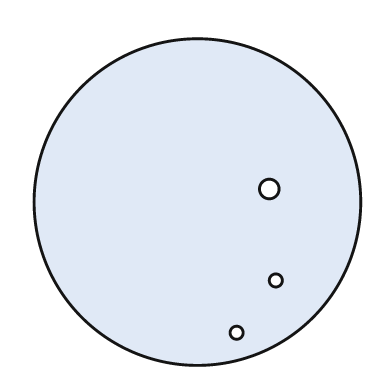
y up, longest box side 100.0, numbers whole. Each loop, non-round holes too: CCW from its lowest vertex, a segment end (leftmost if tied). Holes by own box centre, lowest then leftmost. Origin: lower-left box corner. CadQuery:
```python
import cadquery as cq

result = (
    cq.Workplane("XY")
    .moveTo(50.0, 50.0)
    .circle(50.0)
    .moveTo(62.0, 10.0)
    .circle(2.0)
    .moveTo(74.0, 26.0)
    .circle(2.0)
    .moveTo(72.0, 54.0)
    .circle(3.0)
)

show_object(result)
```